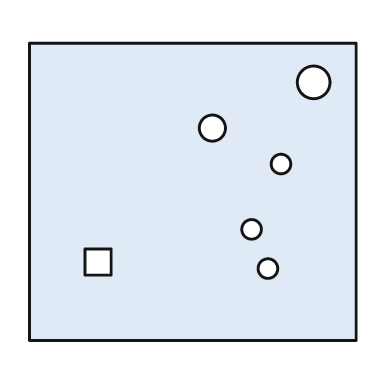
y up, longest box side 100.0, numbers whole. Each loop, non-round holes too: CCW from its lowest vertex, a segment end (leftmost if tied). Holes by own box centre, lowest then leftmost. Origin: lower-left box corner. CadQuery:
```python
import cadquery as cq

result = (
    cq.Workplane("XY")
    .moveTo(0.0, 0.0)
    .lineTo(100.0, 0.0)
    .lineTo(100.0, 91.0)
    .lineTo(0.0, 91.0)
    .close()
    .moveTo(73.0, 22.0)
    .circle(3.0)
    .moveTo(17.0, 20.0)
    .lineTo(25.0, 20.0)
    .lineTo(25.0, 28.0)
    .lineTo(17.0, 28.0)
    .close()
    .moveTo(68.0, 34.0)
    .circle(3.0)
    .moveTo(77.0, 54.0)
    .circle(3.0)
    .moveTo(56.0, 65.0)
    .circle(4.0)
    .moveTo(87.0, 79.0)
    .circle(5.0)
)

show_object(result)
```